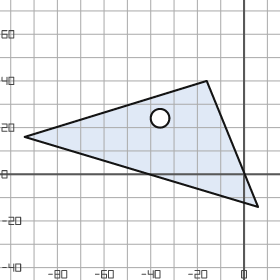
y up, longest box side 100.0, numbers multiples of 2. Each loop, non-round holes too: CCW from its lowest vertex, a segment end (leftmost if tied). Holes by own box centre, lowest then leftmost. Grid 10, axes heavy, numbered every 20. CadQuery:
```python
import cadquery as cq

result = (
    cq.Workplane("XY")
    .moveTo(6.0, -14.0)
    .lineTo(-16.0, 40.0)
    .lineTo(-94.0, 16.0)
    .close()
    .moveTo(-36.0, 24.0)
    .circle(4.0)
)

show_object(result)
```